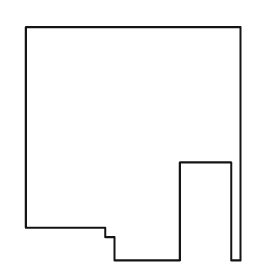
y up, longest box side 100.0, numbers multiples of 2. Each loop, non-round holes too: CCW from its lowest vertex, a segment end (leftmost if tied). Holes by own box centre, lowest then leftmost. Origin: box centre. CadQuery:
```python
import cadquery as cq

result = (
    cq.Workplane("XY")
    .moveTo(-8.0, -50.0)
    .lineTo(20.0, -50.0)
    .lineTo(20.0, -8.0)
    .lineTo(42.0, -8.0)
    .lineTo(42.0, -50.0)
    .lineTo(46.0, -50.0)
    .lineTo(46.0, 50.0)
    .lineTo(-46.0, 50.0)
    .lineTo(-46.0, -36.0)
    .lineTo(-12.0, -36.0)
    .lineTo(-12.0, -40.0)
    .lineTo(-8.0, -40.0)
    .close()
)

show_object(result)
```